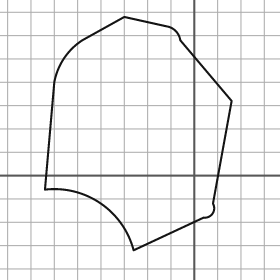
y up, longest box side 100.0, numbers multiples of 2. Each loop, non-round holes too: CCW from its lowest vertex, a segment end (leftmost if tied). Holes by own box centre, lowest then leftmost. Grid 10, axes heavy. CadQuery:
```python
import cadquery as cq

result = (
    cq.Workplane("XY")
    .moveTo(-26.0, -32.0)
    .lineTo(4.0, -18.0)
    .threePointArc((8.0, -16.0), (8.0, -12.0))
    .lineTo(16.0, 32.0)
    .lineTo(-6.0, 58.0)
    .threePointArc((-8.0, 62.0), (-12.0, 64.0))
    .lineTo(-30.0, 68.0)
    .lineTo(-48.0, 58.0)
    .threePointArc((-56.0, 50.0), (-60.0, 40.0))
    .lineTo(-64.0, -6.0)
    .threePointArc((-40.0, -12.0), (-26.0, -32.0))
    .close()
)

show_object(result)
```